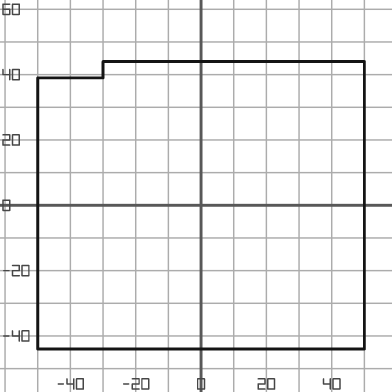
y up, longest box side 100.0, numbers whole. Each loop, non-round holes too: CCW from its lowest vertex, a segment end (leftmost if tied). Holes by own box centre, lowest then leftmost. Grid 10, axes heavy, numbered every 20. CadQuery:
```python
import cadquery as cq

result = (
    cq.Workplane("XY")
    .moveTo(-50.0, -44.0)
    .lineTo(50.0, -44.0)
    .lineTo(50.0, 44.0)
    .lineTo(-30.0, 44.0)
    .lineTo(-30.0, 39.0)
    .lineTo(-50.0, 39.0)
    .close()
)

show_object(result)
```